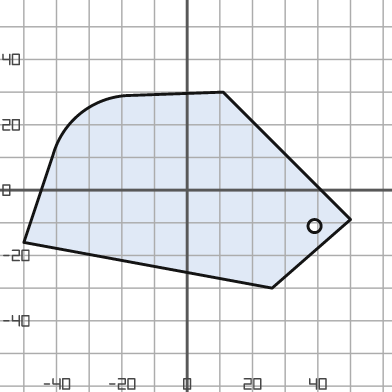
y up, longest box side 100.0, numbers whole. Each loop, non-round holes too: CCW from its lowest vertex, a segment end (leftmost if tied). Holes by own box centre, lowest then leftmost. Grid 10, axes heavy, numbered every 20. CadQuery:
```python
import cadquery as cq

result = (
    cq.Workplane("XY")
    .moveTo(26.0, -30.0)
    .lineTo(50.0, -9.0)
    .lineTo(11.0, 30.0)
    .lineTo(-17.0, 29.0)
    .threePointArc((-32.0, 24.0), (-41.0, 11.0))
    .lineTo(-50.0, -16.0)
    .close()
    .moveTo(39.0, -11.0)
    .circle(2.0)
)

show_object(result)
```